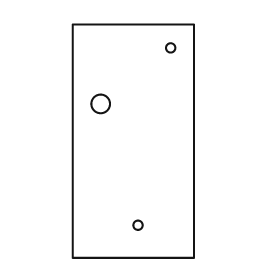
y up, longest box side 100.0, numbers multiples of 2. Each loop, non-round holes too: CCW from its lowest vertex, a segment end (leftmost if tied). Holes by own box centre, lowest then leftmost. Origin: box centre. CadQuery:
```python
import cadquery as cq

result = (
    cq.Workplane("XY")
    .moveTo(-26.0, -50.0)
    .lineTo(26.0, -50.0)
    .lineTo(26.0, 50.0)
    .lineTo(-26.0, 50.0)
    .close()
    .moveTo(2.0, -36.0)
    .circle(2.0)
    .moveTo(-14.0, 16.0)
    .circle(4.0)
    .moveTo(16.0, 40.0)
    .circle(2.0)
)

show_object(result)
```